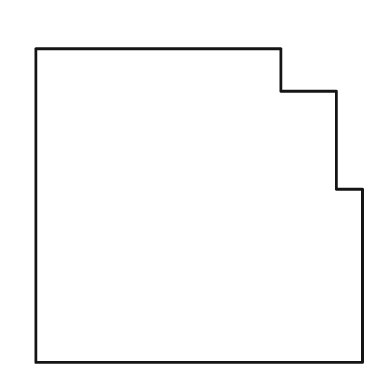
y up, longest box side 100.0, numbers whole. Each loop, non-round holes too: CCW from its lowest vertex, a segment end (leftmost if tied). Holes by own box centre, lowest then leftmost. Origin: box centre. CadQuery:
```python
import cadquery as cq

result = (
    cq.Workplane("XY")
    .moveTo(-50.0, -48.0)
    .lineTo(50.0, -48.0)
    .lineTo(50.0, 5.0)
    .lineTo(42.0, 5.0)
    .lineTo(42.0, 35.0)
    .lineTo(25.0, 35.0)
    .lineTo(25.0, 48.0)
    .lineTo(-50.0, 48.0)
    .close()
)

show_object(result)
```